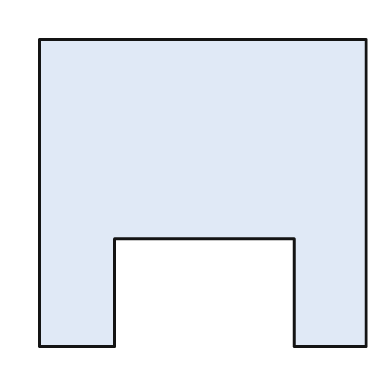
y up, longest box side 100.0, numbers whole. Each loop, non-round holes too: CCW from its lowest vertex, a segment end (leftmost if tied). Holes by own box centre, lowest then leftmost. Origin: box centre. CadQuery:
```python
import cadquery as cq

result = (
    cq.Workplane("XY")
    .moveTo(-50.0, -47.0)
    .lineTo(-27.0, -47.0)
    .lineTo(-27.0, -14.0)
    .lineTo(28.0, -14.0)
    .lineTo(28.0, -47.0)
    .lineTo(50.0, -47.0)
    .lineTo(50.0, 47.0)
    .lineTo(-50.0, 47.0)
    .close()
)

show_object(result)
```